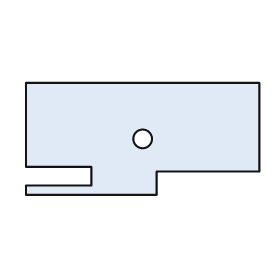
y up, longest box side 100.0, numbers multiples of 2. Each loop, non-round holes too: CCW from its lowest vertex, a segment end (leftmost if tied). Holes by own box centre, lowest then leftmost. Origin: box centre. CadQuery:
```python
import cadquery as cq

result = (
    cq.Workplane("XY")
    .moveTo(-50.0, -24.0)
    .lineTo(6.0, -24.0)
    .lineTo(6.0, -14.0)
    .lineTo(50.0, -14.0)
    .lineTo(50.0, 24.0)
    .lineTo(-50.0, 24.0)
    .lineTo(-50.0, -12.0)
    .lineTo(-22.0, -12.0)
    .lineTo(-22.0, -20.0)
    .lineTo(-50.0, -20.0)
    .close()
    .moveTo(0.0, 0.0)
    .circle(4.0)
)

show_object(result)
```